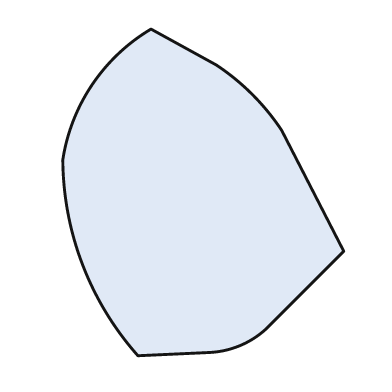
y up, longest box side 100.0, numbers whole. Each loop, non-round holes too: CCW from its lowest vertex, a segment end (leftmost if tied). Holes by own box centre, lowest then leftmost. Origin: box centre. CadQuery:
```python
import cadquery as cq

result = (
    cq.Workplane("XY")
    .moveTo(-20.0, -50.0)
    .lineTo(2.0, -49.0)
    .threePointArc((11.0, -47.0), (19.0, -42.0))
    .lineTo(43.0, -18.0)
    .lineTo(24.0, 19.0)
    .threePointArc((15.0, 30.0), (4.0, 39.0))
    .lineTo(-16.0, 50.0)
    .threePointArc((-34.0, 33.0), (-43.0, 10.0))
    .threePointArc((-37.0, -22.0), (-20.0, -50.0))
    .close()
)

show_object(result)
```